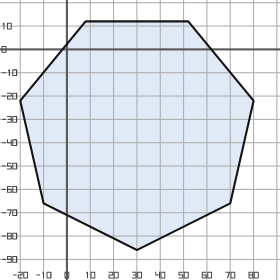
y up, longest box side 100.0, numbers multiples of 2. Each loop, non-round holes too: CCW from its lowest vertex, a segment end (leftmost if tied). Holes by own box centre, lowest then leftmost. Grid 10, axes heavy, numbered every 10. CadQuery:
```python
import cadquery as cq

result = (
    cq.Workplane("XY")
    .moveTo(30.0, -86.0)
    .lineTo(70.0, -66.0)
    .lineTo(80.0, -22.0)
    .lineTo(52.0, 12.0)
    .lineTo(8.0, 12.0)
    .lineTo(-20.0, -22.0)
    .lineTo(-10.0, -66.0)
    .close()
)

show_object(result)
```